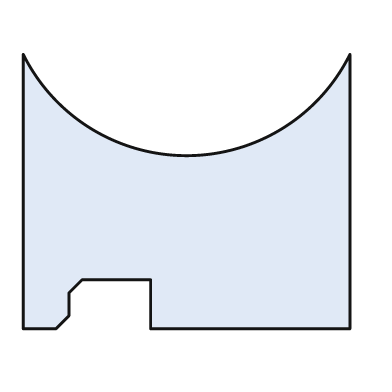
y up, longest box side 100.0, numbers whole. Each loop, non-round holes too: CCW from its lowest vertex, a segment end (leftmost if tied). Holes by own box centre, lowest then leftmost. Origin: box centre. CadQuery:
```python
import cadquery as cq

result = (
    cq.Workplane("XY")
    .moveTo(-50.0, -42.0)
    .lineTo(-40.0, -42.0)
    .lineTo(-36.0, -38.0)
    .lineTo(-36.0, -31.0)
    .lineTo(-32.0, -27.0)
    .lineTo(-11.0, -27.0)
    .lineTo(-11.0, -42.0)
    .lineTo(50.0, -42.0)
    .lineTo(50.0, 42.0)
    .threePointArc((0.0, 11.0), (-50.0, 42.0))
    .close()
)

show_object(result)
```